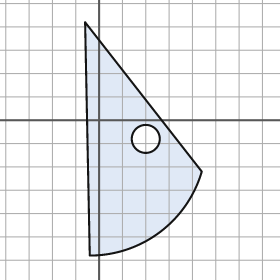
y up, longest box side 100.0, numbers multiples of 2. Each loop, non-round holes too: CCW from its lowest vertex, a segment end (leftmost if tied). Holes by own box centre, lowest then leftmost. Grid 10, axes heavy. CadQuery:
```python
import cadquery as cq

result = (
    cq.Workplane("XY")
    .moveTo(-4.0, -58.0)
    .threePointArc((26.0, -48.0), (44.0, -22.0))
    .lineTo(-6.0, 42.0)
    .close()
    .moveTo(20.0, -8.0)
    .circle(6.0)
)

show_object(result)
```